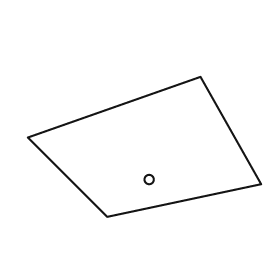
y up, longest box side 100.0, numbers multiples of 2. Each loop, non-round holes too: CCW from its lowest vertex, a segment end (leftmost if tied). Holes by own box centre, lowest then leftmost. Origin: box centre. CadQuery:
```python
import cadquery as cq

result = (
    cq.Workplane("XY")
    .moveTo(-16.0, -30.0)
    .lineTo(50.0, -16.0)
    .lineTo(24.0, 30.0)
    .lineTo(-50.0, 4.0)
    .close()
    .moveTo(2.0, -14.0)
    .circle(2.0)
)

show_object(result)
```